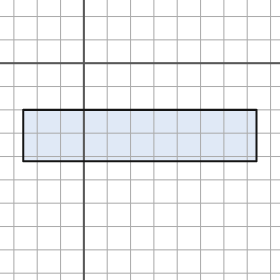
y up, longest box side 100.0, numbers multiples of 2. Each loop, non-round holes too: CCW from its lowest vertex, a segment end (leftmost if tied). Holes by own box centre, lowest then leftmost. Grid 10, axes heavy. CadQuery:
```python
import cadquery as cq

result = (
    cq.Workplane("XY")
    .moveTo(-26.0, -42.0)
    .lineTo(74.0, -42.0)
    .lineTo(74.0, -20.0)
    .lineTo(-26.0, -20.0)
    .close()
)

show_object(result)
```